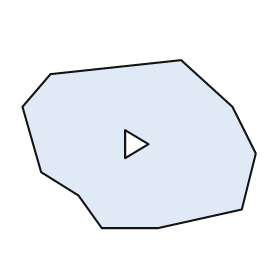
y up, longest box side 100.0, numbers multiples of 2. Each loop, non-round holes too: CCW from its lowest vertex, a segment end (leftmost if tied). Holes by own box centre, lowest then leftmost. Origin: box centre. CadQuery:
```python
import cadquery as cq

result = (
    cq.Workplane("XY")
    .moveTo(-16.0, -36.0)
    .lineTo(8.0, -36.0)
    .lineTo(44.0, -28.0)
    .lineTo(50.0, -4.0)
    .lineTo(40.0, 16.0)
    .lineTo(18.0, 36.0)
    .lineTo(-38.0, 30.0)
    .lineTo(-50.0, 16.0)
    .lineTo(-42.0, -12.0)
    .lineTo(-26.0, -22.0)
    .close()
    .moveTo(-6.0, -6.0)
    .lineTo(4.0, 0.0)
    .lineTo(-6.0, 6.0)
    .close()
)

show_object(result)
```